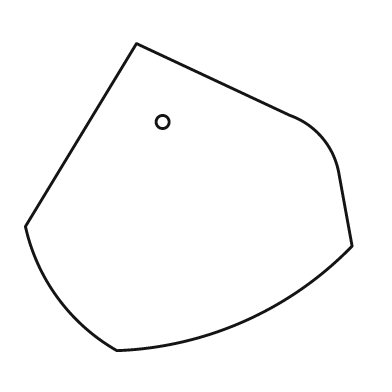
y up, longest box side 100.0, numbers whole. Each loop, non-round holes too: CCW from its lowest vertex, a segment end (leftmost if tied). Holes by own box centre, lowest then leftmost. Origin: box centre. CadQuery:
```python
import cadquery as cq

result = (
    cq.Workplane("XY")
    .moveTo(-22.0, -47.0)
    .threePointArc((17.0, -38.0), (50.0, -15.0))
    .lineTo(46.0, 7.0)
    .threePointArc((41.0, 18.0), (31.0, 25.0))
    .lineTo(-16.0, 47.0)
    .lineTo(-50.0, -9.0)
    .threePointArc((-40.0, -31.0), (-22.0, -47.0))
    .close()
    .moveTo(-8.0, 23.0)
    .circle(2.0)
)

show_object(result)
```